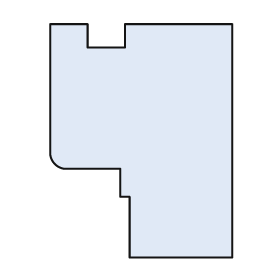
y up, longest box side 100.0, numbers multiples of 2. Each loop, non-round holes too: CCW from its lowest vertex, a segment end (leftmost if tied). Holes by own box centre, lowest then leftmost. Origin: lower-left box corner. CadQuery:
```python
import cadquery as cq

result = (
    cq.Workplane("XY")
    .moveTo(34.0, 0.0)
    .lineTo(78.0, 0.0)
    .lineTo(78.0, 100.0)
    .lineTo(32.0, 100.0)
    .lineTo(32.0, 90.0)
    .lineTo(16.0, 90.0)
    .lineTo(16.0, 100.0)
    .lineTo(0.0, 100.0)
    .lineTo(0.0, 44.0)
    .threePointArc((2.0, 40.0), (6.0, 38.0))
    .lineTo(30.0, 38.0)
    .lineTo(30.0, 26.0)
    .lineTo(34.0, 26.0)
    .close()
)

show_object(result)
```